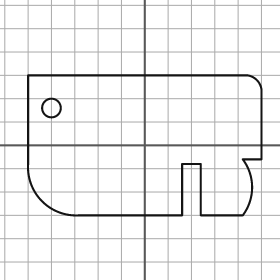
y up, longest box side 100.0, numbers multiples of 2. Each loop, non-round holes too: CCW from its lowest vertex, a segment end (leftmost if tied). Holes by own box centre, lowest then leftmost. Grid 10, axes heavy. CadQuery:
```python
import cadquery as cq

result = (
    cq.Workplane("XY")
    .moveTo(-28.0, -30.0)
    .lineTo(16.0, -30.0)
    .lineTo(16.0, -8.0)
    .lineTo(24.0, -8.0)
    .lineTo(24.0, -30.0)
    .lineTo(42.0, -30.0)
    .threePointArc((46.0, -18.0), (42.0, -6.0))
    .lineTo(50.0, -6.0)
    .lineTo(50.0, 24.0)
    .threePointArc((48.0, 28.0), (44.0, 30.0))
    .lineTo(-50.0, 30.0)
    .lineTo(-50.0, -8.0)
    .threePointArc((-44.0, -24.0), (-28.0, -30.0))
    .close()
    .moveTo(-40.0, 16.0)
    .circle(4.0)
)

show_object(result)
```